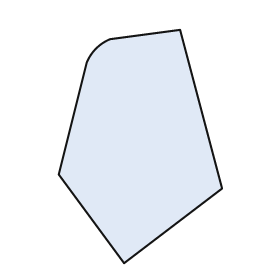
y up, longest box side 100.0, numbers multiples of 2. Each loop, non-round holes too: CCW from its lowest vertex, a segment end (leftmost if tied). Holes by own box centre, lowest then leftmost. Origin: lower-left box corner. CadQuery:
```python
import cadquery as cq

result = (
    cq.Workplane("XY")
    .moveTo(28.0, 0.0)
    .lineTo(70.0, 32.0)
    .lineTo(52.0, 100.0)
    .lineTo(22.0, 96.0)
    .threePointArc((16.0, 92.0), (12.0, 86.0))
    .lineTo(0.0, 38.0)
    .close()
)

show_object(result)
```